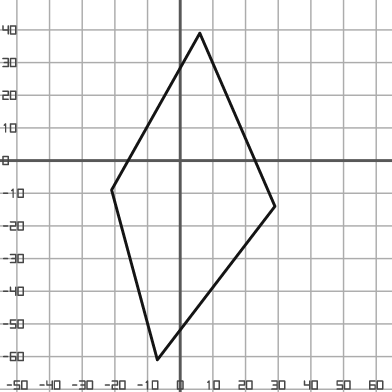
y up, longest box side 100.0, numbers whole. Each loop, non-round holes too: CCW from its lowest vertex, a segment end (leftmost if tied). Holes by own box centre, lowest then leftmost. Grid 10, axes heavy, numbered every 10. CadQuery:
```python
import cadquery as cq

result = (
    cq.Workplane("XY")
    .moveTo(-7.0, -61.0)
    .lineTo(29.0, -14.0)
    .lineTo(6.0, 39.0)
    .lineTo(-21.0, -9.0)
    .close()
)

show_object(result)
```